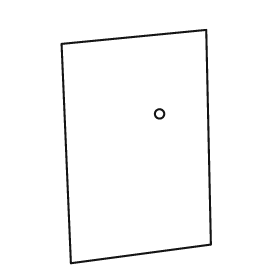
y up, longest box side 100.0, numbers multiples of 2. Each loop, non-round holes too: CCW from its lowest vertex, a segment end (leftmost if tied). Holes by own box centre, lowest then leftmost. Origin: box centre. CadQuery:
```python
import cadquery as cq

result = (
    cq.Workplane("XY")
    .moveTo(-28.0, -50.0)
    .lineTo(32.0, -42.0)
    .lineTo(30.0, 50.0)
    .lineTo(-32.0, 44.0)
    .close()
    .moveTo(10.0, 14.0)
    .circle(2.0)
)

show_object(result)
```